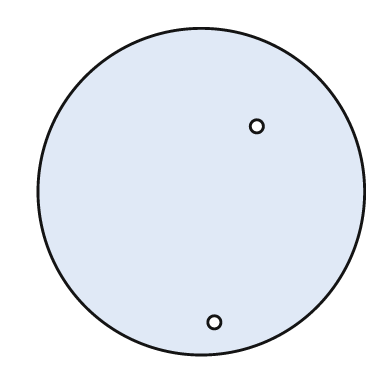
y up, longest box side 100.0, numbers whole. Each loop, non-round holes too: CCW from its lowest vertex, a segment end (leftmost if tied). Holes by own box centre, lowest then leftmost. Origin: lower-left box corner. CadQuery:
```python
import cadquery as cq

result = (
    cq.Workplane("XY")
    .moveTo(50.0, 50.0)
    .circle(50.0)
    .moveTo(54.0, 10.0)
    .circle(2.0)
    .moveTo(67.0, 70.0)
    .circle(2.0)
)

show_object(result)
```